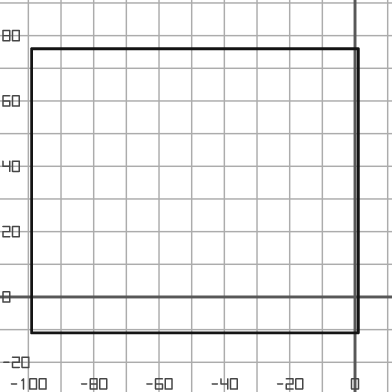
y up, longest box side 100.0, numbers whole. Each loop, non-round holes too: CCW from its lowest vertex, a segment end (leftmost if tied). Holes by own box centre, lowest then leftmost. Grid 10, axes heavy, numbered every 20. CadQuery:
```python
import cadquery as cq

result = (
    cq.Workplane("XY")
    .moveTo(-99.0, -11.0)
    .lineTo(1.0, -11.0)
    .lineTo(1.0, 76.0)
    .lineTo(-99.0, 76.0)
    .close()
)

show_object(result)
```